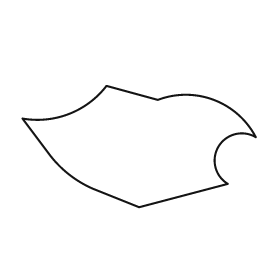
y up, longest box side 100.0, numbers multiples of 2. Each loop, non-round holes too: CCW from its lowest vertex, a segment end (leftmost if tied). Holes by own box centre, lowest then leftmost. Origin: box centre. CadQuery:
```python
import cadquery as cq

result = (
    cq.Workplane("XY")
    .moveTo(0.0, -26.0)
    .lineTo(38.0, -16.0)
    .threePointArc((34.0, 0.0), (50.0, 4.0))
    .threePointArc((32.0, 20.0), (8.0, 20.0))
    .lineTo(-14.0, 26.0)
    .threePointArc((-30.0, 14.0), (-50.0, 12.0))
    .lineTo(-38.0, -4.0)
    .threePointArc((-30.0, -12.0), (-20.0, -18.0))
    .close()
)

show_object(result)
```